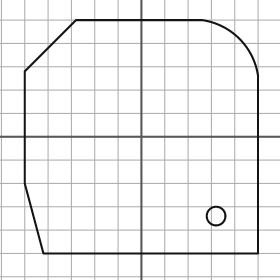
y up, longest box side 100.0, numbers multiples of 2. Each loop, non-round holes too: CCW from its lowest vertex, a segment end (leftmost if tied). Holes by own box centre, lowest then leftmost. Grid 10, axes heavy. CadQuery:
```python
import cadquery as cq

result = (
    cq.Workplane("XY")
    .moveTo(-42.0, -50.0)
    .lineTo(50.0, -50.0)
    .lineTo(50.0, 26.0)
    .threePointArc((42.0, 42.0), (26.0, 50.0))
    .lineTo(-28.0, 50.0)
    .lineTo(-50.0, 28.0)
    .lineTo(-50.0, -20.0)
    .close()
    .moveTo(32.0, -34.0)
    .circle(4.0)
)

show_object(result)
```